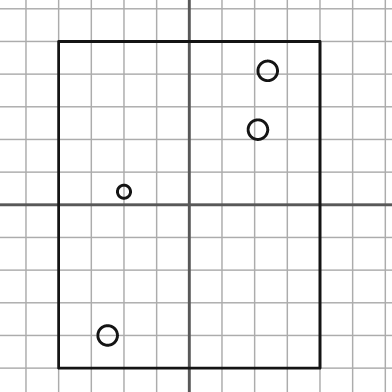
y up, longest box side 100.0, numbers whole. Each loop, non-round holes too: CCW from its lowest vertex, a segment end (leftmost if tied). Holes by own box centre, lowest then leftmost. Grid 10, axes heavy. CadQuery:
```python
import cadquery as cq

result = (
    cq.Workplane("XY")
    .moveTo(-40.0, -50.0)
    .lineTo(40.0, -50.0)
    .lineTo(40.0, 50.0)
    .lineTo(-40.0, 50.0)
    .close()
    .moveTo(-25.0, -40.0)
    .circle(3.0)
    .moveTo(-20.0, 4.0)
    .circle(2.0)
    .moveTo(21.0, 23.0)
    .circle(3.0)
    .moveTo(24.0, 41.0)
    .circle(3.0)
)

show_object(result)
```